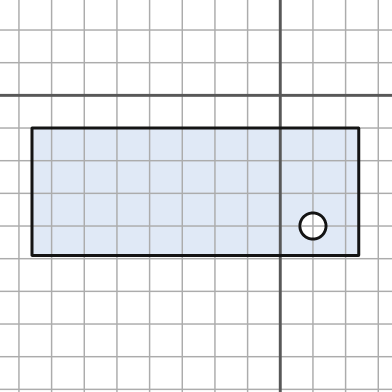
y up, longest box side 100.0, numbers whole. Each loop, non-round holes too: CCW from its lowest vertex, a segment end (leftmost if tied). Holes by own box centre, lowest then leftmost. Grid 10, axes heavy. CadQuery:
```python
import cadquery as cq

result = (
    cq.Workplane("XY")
    .moveTo(-76.0, -49.0)
    .lineTo(24.0, -49.0)
    .lineTo(24.0, -10.0)
    .lineTo(-76.0, -10.0)
    .close()
    .moveTo(10.0, -40.0)
    .circle(4.0)
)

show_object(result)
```